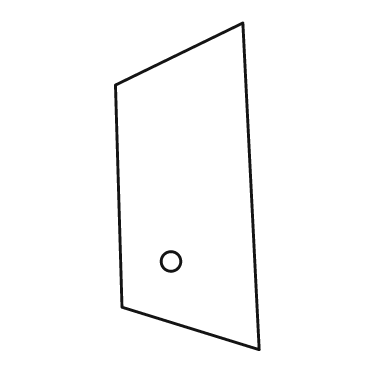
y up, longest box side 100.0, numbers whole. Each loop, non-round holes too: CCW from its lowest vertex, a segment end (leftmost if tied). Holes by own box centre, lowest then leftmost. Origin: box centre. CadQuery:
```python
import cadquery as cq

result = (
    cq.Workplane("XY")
    .moveTo(22.0, -50.0)
    .lineTo(17.0, 50.0)
    .lineTo(-22.0, 31.0)
    .lineTo(-20.0, -37.0)
    .close()
    .moveTo(-5.0, -23.0)
    .circle(3.0)
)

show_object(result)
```